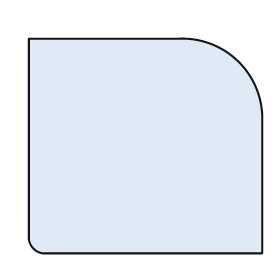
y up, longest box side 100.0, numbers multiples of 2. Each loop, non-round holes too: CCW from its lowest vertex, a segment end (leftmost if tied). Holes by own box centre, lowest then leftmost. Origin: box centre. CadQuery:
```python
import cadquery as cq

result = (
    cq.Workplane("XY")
    .moveTo(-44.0, -46.0)
    .lineTo(50.0, -46.0)
    .lineTo(50.0, 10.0)
    .threePointArc((40.0, 36.0), (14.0, 46.0))
    .lineTo(-50.0, 46.0)
    .lineTo(-50.0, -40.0)
    .threePointArc((-48.0, -44.0), (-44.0, -46.0))
    .close()
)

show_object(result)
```